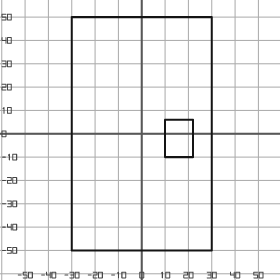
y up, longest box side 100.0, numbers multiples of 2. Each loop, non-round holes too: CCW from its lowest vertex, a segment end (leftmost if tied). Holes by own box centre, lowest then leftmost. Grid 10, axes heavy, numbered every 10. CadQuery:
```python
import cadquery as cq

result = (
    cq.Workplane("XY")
    .moveTo(-30.0, -50.0)
    .lineTo(30.0, -50.0)
    .lineTo(30.0, 50.0)
    .lineTo(-30.0, 50.0)
    .close()
    .moveTo(10.0, -10.0)
    .lineTo(22.0, -10.0)
    .lineTo(22.0, 6.0)
    .lineTo(10.0, 6.0)
    .close()
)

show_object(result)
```